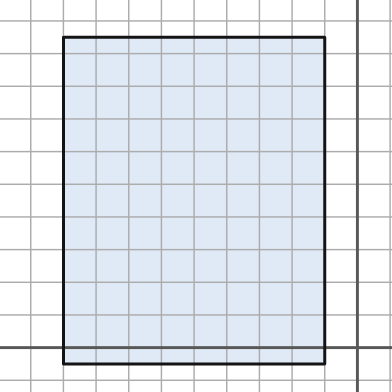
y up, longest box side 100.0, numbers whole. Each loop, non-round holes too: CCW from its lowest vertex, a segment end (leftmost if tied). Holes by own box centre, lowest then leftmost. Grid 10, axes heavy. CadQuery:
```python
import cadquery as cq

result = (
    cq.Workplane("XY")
    .moveTo(-90.0, -5.0)
    .lineTo(-10.0, -5.0)
    .lineTo(-10.0, 95.0)
    .lineTo(-90.0, 95.0)
    .close()
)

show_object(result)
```